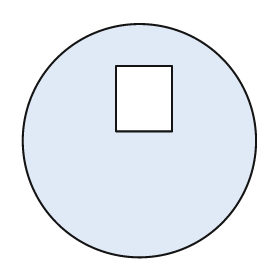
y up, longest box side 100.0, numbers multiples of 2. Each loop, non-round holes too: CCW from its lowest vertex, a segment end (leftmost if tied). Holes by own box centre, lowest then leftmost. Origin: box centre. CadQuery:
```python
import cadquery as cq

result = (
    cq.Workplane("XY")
    .moveTo(0.0, 0.0)
    .circle(50.0)
    .moveTo(-10.0, 4.0)
    .lineTo(14.0, 4.0)
    .lineTo(14.0, 32.0)
    .lineTo(-10.0, 32.0)
    .close()
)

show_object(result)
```